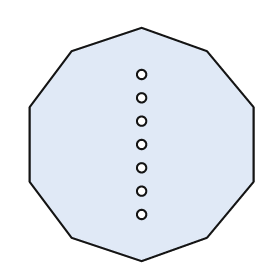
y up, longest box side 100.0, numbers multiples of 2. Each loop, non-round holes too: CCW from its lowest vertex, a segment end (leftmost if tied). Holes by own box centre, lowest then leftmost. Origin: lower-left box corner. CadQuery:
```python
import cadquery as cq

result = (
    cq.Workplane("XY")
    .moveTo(48.0, 0.0)
    .lineTo(76.0, 10.0)
    .lineTo(96.0, 34.0)
    .lineTo(96.0, 66.0)
    .lineTo(76.0, 90.0)
    .lineTo(48.0, 100.0)
    .lineTo(18.0, 90.0)
    .lineTo(0.0, 66.0)
    .lineTo(0.0, 34.0)
    .lineTo(18.0, 10.0)
    .close()
    .moveTo(48.0, 20.0)
    .circle(2.0)
    .moveTo(48.0, 30.0)
    .circle(2.0)
    .moveTo(48.0, 40.0)
    .circle(2.0)
    .moveTo(48.0, 50.0)
    .circle(2.0)
    .moveTo(48.0, 60.0)
    .circle(2.0)
    .moveTo(48.0, 70.0)
    .circle(2.0)
    .moveTo(48.0, 80.0)
    .circle(2.0)
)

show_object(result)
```